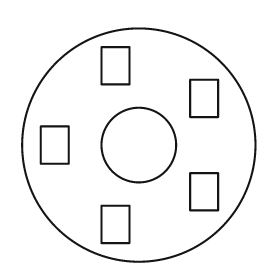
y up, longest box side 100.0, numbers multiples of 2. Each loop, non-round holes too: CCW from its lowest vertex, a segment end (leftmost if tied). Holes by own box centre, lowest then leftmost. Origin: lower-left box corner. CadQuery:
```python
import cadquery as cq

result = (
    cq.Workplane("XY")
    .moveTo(50.0, 50.0)
    .circle(50.0)
    .moveTo(34.0, 8.0)
    .lineTo(46.0, 8.0)
    .lineTo(46.0, 24.0)
    .lineTo(34.0, 24.0)
    .close()
    .moveTo(72.0, 22.0)
    .lineTo(84.0, 22.0)
    .lineTo(84.0, 38.0)
    .lineTo(72.0, 38.0)
    .close()
    .moveTo(8.0, 42.0)
    .lineTo(20.0, 42.0)
    .lineTo(20.0, 58.0)
    .lineTo(8.0, 58.0)
    .close()
    .moveTo(50.0, 50.0)
    .circle(16.0)
    .moveTo(72.0, 62.0)
    .lineTo(84.0, 62.0)
    .lineTo(84.0, 78.0)
    .lineTo(72.0, 78.0)
    .close()
    .moveTo(34.0, 76.0)
    .lineTo(46.0, 76.0)
    .lineTo(46.0, 92.0)
    .lineTo(34.0, 92.0)
    .close()
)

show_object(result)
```